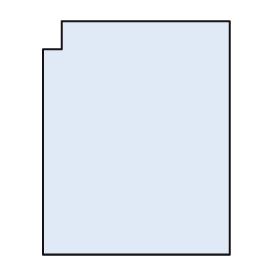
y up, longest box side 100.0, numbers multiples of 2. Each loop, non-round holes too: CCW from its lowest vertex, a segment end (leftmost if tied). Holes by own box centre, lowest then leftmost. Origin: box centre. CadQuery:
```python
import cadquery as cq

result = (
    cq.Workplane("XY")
    .moveTo(-40.0, -50.0)
    .lineTo(40.0, -50.0)
    .lineTo(40.0, 50.0)
    .lineTo(-32.0, 50.0)
    .lineTo(-32.0, 38.0)
    .lineTo(-40.0, 38.0)
    .close()
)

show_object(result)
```